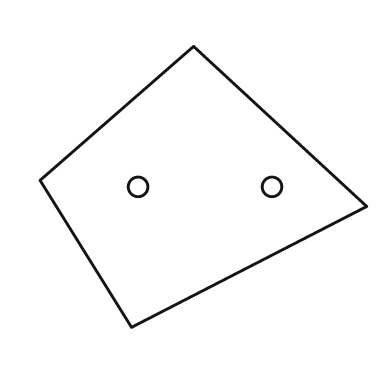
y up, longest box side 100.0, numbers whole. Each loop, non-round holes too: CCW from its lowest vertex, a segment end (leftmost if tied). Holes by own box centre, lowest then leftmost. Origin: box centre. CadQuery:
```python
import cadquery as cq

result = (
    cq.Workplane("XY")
    .moveTo(-22.0, -43.0)
    .lineTo(50.0, -6.0)
    .lineTo(-3.0, 43.0)
    .lineTo(-50.0, 2.0)
    .close()
    .moveTo(-20.0, 0.0)
    .circle(3.0)
    .moveTo(21.0, 0.0)
    .circle(3.0)
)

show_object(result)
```